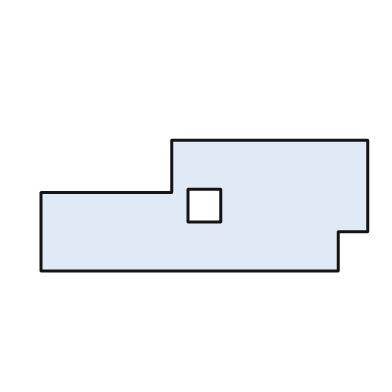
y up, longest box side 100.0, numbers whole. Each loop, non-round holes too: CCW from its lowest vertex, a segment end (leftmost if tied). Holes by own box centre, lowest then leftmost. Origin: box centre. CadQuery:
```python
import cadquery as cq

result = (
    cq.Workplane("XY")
    .moveTo(-50.0, -20.0)
    .lineTo(41.0, -20.0)
    .lineTo(41.0, -8.0)
    .lineTo(50.0, -8.0)
    .lineTo(50.0, 20.0)
    .lineTo(-10.0, 20.0)
    .lineTo(-10.0, 4.0)
    .lineTo(-50.0, 4.0)
    .close()
    .moveTo(-5.0, -5.0)
    .lineTo(5.0, -5.0)
    .lineTo(5.0, 5.0)
    .lineTo(-5.0, 5.0)
    .close()
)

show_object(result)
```